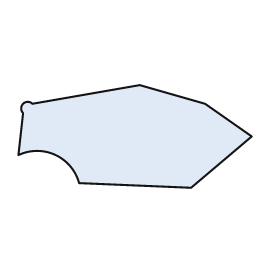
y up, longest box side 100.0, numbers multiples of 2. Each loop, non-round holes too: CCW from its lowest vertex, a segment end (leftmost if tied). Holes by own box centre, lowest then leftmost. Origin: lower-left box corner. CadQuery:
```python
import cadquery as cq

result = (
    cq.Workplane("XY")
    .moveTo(74.0, 0.0)
    .lineTo(100.0, 22.0)
    .lineTo(80.0, 36.0)
    .lineTo(52.0, 44.0)
    .lineTo(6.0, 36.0)
    .threePointArc((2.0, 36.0), (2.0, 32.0))
    .lineTo(0.0, 14.0)
    .threePointArc((16.0, 14.0), (26.0, 2.0))
    .close()
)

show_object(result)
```